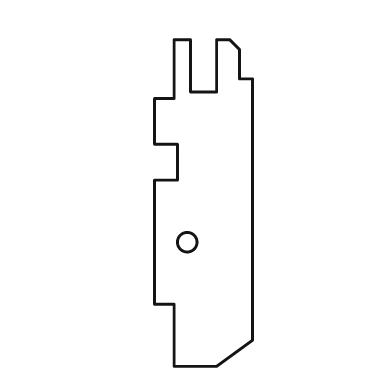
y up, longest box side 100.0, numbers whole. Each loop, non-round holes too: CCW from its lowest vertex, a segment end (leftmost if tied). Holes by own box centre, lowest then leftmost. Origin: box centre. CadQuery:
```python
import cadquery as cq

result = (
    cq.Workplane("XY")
    .moveTo(-9.0, -50.0)
    .lineTo(4.0, -50.0)
    .lineTo(15.0, -42.0)
    .lineTo(15.0, 38.0)
    .lineTo(11.0, 38.0)
    .lineTo(11.0, 47.0)
    .lineTo(8.0, 50.0)
    .lineTo(4.0, 50.0)
    .lineTo(4.0, 34.0)
    .lineTo(-4.0, 34.0)
    .lineTo(-4.0, 50.0)
    .lineTo(-9.0, 50.0)
    .lineTo(-9.0, 32.0)
    .lineTo(-15.0, 32.0)
    .lineTo(-15.0, 18.0)
    .lineTo(-8.0, 18.0)
    .lineTo(-8.0, 7.0)
    .lineTo(-15.0, 7.0)
    .lineTo(-15.0, -31.0)
    .lineTo(-9.0, -31.0)
    .close()
    .moveTo(-5.0, -12.0)
    .circle(3.0)
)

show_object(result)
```